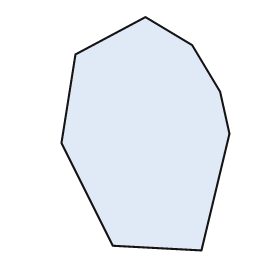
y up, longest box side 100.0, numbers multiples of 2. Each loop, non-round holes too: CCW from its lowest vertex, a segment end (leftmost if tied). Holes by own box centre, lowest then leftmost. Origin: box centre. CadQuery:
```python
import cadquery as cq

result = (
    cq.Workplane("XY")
    .moveTo(24.0, -50.0)
    .lineTo(36.0, 0.0)
    .lineTo(32.0, 18.0)
    .lineTo(20.0, 38.0)
    .lineTo(0.0, 50.0)
    .lineTo(-30.0, 34.0)
    .lineTo(-36.0, -4.0)
    .lineTo(-14.0, -48.0)
    .close()
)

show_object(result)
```